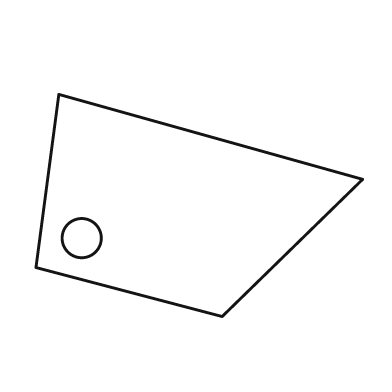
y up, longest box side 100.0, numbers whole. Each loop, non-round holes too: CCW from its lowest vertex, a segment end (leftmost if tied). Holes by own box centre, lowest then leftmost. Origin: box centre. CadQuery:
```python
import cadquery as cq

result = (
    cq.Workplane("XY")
    .moveTo(7.0, -34.0)
    .lineTo(50.0, 8.0)
    .lineTo(-43.0, 34.0)
    .lineTo(-50.0, -19.0)
    .close()
    .moveTo(-36.0, -10.0)
    .circle(6.0)
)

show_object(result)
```